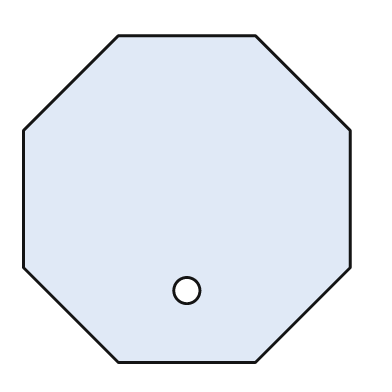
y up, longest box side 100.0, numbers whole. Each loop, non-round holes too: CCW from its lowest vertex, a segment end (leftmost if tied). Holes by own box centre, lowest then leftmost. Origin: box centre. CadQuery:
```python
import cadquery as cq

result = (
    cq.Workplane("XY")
    .moveTo(-21.0, -50.0)
    .lineTo(21.0, -50.0)
    .lineTo(50.0, -21.0)
    .lineTo(50.0, 21.0)
    .lineTo(21.0, 50.0)
    .lineTo(-21.0, 50.0)
    .lineTo(-50.0, 21.0)
    .lineTo(-50.0, -21.0)
    .close()
    .moveTo(0.0, -28.0)
    .circle(4.0)
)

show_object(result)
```